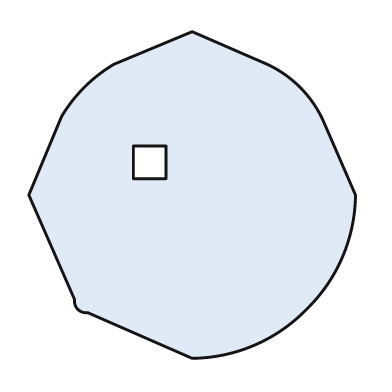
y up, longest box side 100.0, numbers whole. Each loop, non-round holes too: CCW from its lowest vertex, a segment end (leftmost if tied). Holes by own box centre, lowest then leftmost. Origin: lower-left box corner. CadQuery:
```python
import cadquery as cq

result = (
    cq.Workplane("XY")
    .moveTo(50.0, 0.0)
    .threePointArc((69.0, 4.0), (85.0, 15.0))
    .threePointArc((96.0, 31.0), (100.0, 50.0))
    .lineTo(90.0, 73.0)
    .threePointArc((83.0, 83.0), (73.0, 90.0))
    .lineTo(50.0, 100.0)
    .lineTo(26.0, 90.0)
    .threePointArc((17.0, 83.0), (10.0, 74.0))
    .lineTo(0.0, 50.0)
    .lineTo(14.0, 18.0)
    .threePointArc((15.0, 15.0), (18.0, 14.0))
    .close()
    .moveTo(32.0, 55.0)
    .lineTo(42.0, 55.0)
    .lineTo(42.0, 65.0)
    .lineTo(32.0, 65.0)
    .close()
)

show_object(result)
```